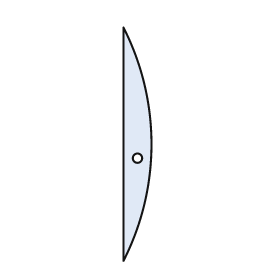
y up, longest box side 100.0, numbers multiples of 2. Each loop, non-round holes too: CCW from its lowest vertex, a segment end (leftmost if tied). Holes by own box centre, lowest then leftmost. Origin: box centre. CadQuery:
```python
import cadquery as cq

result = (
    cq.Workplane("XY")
    .moveTo(-6.0, -50.0)
    .threePointArc((6.0, 0.0), (-6.0, 50.0))
    .close()
    .moveTo(0.0, -6.0)
    .circle(2.0)
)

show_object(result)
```